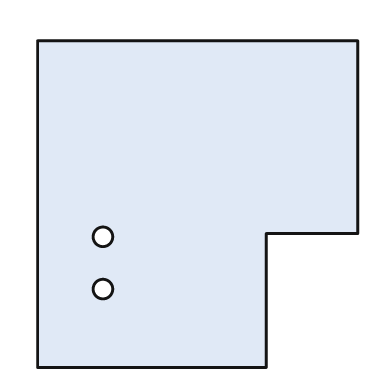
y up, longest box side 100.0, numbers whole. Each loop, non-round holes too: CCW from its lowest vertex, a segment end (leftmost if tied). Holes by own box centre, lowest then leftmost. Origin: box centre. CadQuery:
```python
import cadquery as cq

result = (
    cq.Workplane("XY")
    .moveTo(-49.0, -50.0)
    .lineTo(21.0, -50.0)
    .lineTo(21.0, -9.0)
    .lineTo(49.0, -9.0)
    .lineTo(49.0, 50.0)
    .lineTo(-49.0, 50.0)
    .close()
    .moveTo(-29.0, -26.0)
    .circle(3.0)
    .moveTo(-29.0, -10.0)
    .circle(3.0)
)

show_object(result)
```